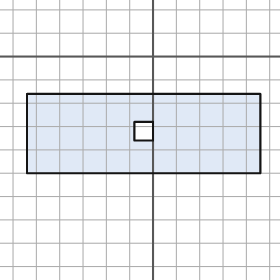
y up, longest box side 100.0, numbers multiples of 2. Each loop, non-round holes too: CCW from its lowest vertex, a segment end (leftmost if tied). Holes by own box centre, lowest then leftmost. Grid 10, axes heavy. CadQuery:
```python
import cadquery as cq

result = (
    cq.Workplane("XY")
    .moveTo(-54.0, -50.0)
    .lineTo(46.0, -50.0)
    .lineTo(46.0, -16.0)
    .lineTo(-54.0, -16.0)
    .close()
    .moveTo(-8.0, -36.0)
    .lineTo(0.0, -36.0)
    .lineTo(0.0, -28.0)
    .lineTo(-8.0, -28.0)
    .close()
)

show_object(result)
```